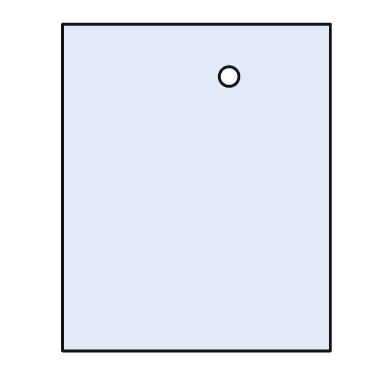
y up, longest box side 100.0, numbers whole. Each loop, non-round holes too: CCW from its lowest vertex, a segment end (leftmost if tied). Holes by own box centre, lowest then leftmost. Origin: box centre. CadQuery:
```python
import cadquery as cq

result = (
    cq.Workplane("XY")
    .moveTo(-41.0, -50.0)
    .lineTo(41.0, -50.0)
    .lineTo(41.0, 50.0)
    .lineTo(-41.0, 50.0)
    .close()
    .moveTo(10.0, 34.0)
    .circle(3.0)
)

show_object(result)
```